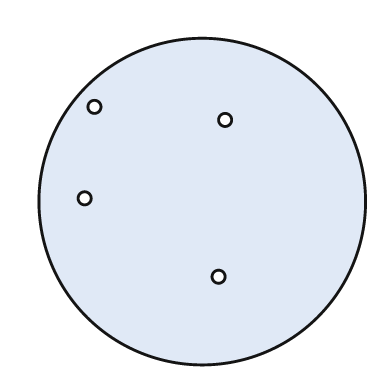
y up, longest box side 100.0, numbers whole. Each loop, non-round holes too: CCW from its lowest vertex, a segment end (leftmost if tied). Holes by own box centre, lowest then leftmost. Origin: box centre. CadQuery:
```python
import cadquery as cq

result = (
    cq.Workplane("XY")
    .moveTo(0.0, 0.0)
    .circle(50.0)
    .moveTo(5.0, -23.0)
    .circle(2.0)
    .moveTo(-36.0, 1.0)
    .circle(2.0)
    .moveTo(7.0, 25.0)
    .circle(2.0)
    .moveTo(-33.0, 29.0)
    .circle(2.0)
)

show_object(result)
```